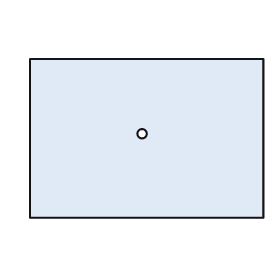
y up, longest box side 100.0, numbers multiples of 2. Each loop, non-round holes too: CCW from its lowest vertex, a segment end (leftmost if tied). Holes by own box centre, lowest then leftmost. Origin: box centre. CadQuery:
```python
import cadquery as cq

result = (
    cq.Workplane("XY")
    .moveTo(-50.0, -34.0)
    .lineTo(50.0, -34.0)
    .lineTo(50.0, 34.0)
    .lineTo(-50.0, 34.0)
    .close()
    .moveTo(-2.0, 2.0)
    .circle(2.0)
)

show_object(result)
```